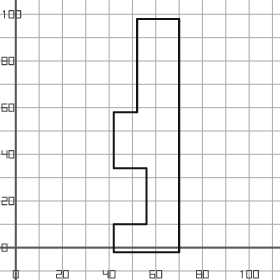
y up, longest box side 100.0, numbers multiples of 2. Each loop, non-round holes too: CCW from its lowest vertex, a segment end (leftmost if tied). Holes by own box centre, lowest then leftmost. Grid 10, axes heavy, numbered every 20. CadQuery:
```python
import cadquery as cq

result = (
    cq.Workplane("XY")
    .moveTo(42.0, -2.0)
    .lineTo(70.0, -2.0)
    .lineTo(70.0, 98.0)
    .lineTo(52.0, 98.0)
    .lineTo(52.0, 58.0)
    .lineTo(42.0, 58.0)
    .lineTo(42.0, 34.0)
    .lineTo(56.0, 34.0)
    .lineTo(56.0, 10.0)
    .lineTo(42.0, 10.0)
    .close()
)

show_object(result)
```